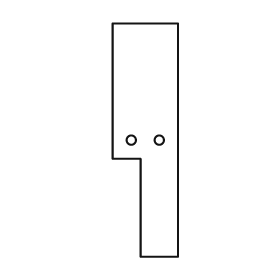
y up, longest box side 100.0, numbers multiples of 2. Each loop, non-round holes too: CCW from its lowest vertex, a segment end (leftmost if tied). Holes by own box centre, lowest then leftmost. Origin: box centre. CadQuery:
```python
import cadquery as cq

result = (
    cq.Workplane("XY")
    .moveTo(-2.0, -50.0)
    .lineTo(14.0, -50.0)
    .lineTo(14.0, 50.0)
    .lineTo(-14.0, 50.0)
    .lineTo(-14.0, -8.0)
    .lineTo(-2.0, -8.0)
    .close()
    .moveTo(-6.0, 0.0)
    .circle(2.0)
    .moveTo(6.0, 0.0)
    .circle(2.0)
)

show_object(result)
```